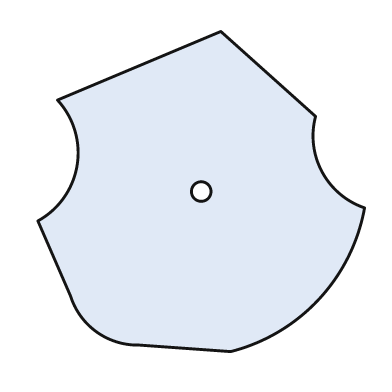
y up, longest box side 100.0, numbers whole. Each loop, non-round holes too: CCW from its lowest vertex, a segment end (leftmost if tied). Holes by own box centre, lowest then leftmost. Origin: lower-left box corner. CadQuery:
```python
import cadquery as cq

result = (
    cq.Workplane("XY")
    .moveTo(59.0, 0.0)
    .threePointArc((86.0, 16.0), (100.0, 44.0))
    .threePointArc((87.0, 55.0), (85.0, 72.0))
    .lineTo(56.0, 98.0)
    .lineTo(6.0, 77.0)
    .threePointArc((12.0, 57.0), (0.0, 40.0))
    .lineTo(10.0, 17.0)
    .threePointArc((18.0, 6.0), (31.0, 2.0))
    .close()
    .moveTo(50.0, 49.0)
    .circle(3.0)
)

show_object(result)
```